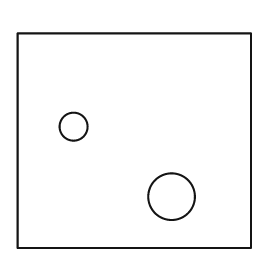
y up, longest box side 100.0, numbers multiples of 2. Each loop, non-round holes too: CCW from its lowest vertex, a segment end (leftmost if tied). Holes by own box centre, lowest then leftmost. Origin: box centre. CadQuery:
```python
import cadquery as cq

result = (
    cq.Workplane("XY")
    .moveTo(-50.0, -46.0)
    .lineTo(50.0, -46.0)
    .lineTo(50.0, 46.0)
    .lineTo(-50.0, 46.0)
    .close()
    .moveTo(16.0, -24.0)
    .circle(10.0)
    .moveTo(-26.0, 6.0)
    .circle(6.0)
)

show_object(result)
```